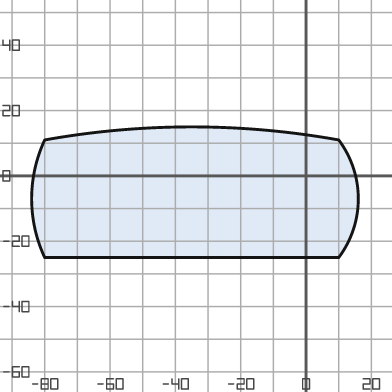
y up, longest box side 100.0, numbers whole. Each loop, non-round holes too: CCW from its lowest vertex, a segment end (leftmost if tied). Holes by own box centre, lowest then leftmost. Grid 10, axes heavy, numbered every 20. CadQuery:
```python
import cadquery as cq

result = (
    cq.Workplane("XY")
    .moveTo(-80.0, -25.0)
    .lineTo(10.0, -25.0)
    .threePointArc((16.0, -7.0), (10.0, 11.0))
    .threePointArc((-35.0, 15.0), (-80.0, 11.0))
    .threePointArc((-84.0, -7.0), (-80.0, -25.0))
    .close()
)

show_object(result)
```